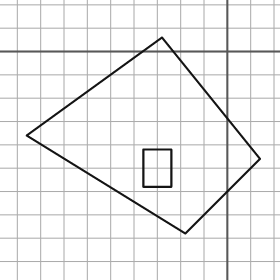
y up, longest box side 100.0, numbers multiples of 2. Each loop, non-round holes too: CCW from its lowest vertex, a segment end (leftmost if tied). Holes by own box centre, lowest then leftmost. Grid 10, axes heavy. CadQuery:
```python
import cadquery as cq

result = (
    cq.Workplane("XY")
    .moveTo(-18.0, -78.0)
    .lineTo(14.0, -46.0)
    .lineTo(-28.0, 6.0)
    .lineTo(-86.0, -36.0)
    .close()
    .moveTo(-36.0, -58.0)
    .lineTo(-24.0, -58.0)
    .lineTo(-24.0, -42.0)
    .lineTo(-36.0, -42.0)
    .close()
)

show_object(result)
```